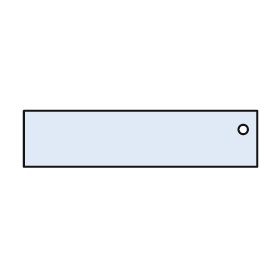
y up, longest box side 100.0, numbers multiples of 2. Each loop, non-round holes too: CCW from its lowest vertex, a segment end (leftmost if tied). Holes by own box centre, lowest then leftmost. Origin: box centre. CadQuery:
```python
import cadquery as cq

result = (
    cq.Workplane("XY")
    .moveTo(-50.0, -12.0)
    .lineTo(50.0, -12.0)
    .lineTo(50.0, 12.0)
    .lineTo(-50.0, 12.0)
    .close()
    .moveTo(44.0, 4.0)
    .circle(2.0)
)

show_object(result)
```